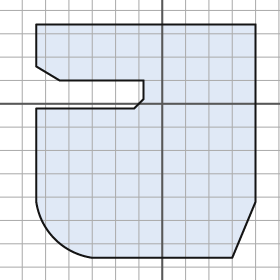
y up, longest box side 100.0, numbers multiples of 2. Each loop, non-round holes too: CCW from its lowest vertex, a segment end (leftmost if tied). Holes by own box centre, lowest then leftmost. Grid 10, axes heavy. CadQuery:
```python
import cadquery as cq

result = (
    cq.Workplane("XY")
    .moveTo(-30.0, -66.0)
    .lineTo(30.0, -66.0)
    .lineTo(40.0, -42.0)
    .lineTo(40.0, 34.0)
    .lineTo(-54.0, 34.0)
    .lineTo(-54.0, 16.0)
    .lineTo(-44.0, 10.0)
    .lineTo(-8.0, 10.0)
    .lineTo(-8.0, 2.0)
    .lineTo(-12.0, -2.0)
    .lineTo(-54.0, -2.0)
    .lineTo(-54.0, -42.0)
    .threePointArc((-46.0, -58.0), (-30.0, -66.0))
    .close()
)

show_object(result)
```